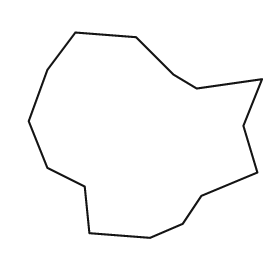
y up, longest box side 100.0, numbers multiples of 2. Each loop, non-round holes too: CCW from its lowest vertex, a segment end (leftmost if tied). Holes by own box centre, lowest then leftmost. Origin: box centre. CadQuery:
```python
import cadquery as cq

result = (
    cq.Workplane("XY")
    .moveTo(2.0, -44.0)
    .lineTo(16.0, -38.0)
    .lineTo(24.0, -26.0)
    .lineTo(48.0, -16.0)
    .lineTo(42.0, 4.0)
    .lineTo(50.0, 24.0)
    .lineTo(22.0, 20.0)
    .lineTo(12.0, 26.0)
    .lineTo(-4.0, 42.0)
    .lineTo(-30.0, 44.0)
    .lineTo(-42.0, 28.0)
    .lineTo(-50.0, 6.0)
    .lineTo(-42.0, -14.0)
    .lineTo(-26.0, -22.0)
    .lineTo(-24.0, -42.0)
    .close()
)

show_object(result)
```